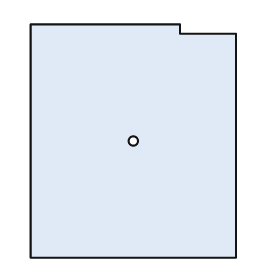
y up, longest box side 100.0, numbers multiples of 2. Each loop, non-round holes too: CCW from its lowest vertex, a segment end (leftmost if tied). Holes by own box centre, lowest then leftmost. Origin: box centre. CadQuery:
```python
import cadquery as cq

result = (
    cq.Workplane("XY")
    .moveTo(-44.0, -50.0)
    .lineTo(44.0, -50.0)
    .lineTo(44.0, 46.0)
    .lineTo(20.0, 46.0)
    .lineTo(20.0, 50.0)
    .lineTo(-44.0, 50.0)
    .close()
    .moveTo(0.0, 0.0)
    .circle(2.0)
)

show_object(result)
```